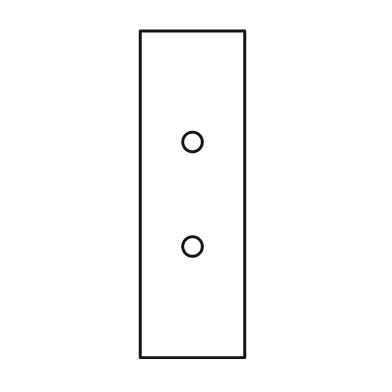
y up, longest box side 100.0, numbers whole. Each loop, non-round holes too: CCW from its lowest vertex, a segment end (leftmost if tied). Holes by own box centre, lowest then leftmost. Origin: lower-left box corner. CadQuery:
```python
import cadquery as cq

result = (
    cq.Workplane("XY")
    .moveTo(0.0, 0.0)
    .lineTo(32.0, 0.0)
    .lineTo(32.0, 100.0)
    .lineTo(0.0, 100.0)
    .close()
    .moveTo(16.0, 34.0)
    .circle(3.0)
    .moveTo(16.0, 66.0)
    .circle(3.0)
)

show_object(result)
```